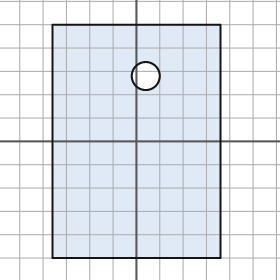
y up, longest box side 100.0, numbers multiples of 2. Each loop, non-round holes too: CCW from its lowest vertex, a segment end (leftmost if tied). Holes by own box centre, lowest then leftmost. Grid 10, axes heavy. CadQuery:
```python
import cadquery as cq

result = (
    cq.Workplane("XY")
    .moveTo(-36.0, -50.0)
    .lineTo(36.0, -50.0)
    .lineTo(36.0, 50.0)
    .lineTo(-36.0, 50.0)
    .close()
    .moveTo(4.0, 28.0)
    .circle(6.0)
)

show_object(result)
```